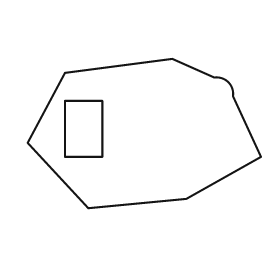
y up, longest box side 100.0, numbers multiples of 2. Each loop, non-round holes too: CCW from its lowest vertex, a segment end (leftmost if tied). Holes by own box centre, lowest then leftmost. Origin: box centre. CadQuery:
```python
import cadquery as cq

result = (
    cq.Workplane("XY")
    .moveTo(-24.0, -32.0)
    .lineTo(18.0, -28.0)
    .lineTo(50.0, -10.0)
    .lineTo(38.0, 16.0)
    .threePointArc((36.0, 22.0), (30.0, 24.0))
    .lineTo(12.0, 32.0)
    .lineTo(-34.0, 26.0)
    .lineTo(-50.0, -4.0)
    .close()
    .moveTo(-34.0, -10.0)
    .lineTo(-18.0, -10.0)
    .lineTo(-18.0, 14.0)
    .lineTo(-34.0, 14.0)
    .close()
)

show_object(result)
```